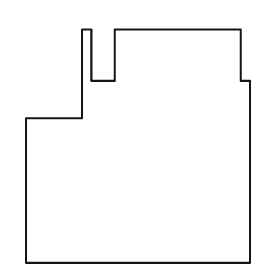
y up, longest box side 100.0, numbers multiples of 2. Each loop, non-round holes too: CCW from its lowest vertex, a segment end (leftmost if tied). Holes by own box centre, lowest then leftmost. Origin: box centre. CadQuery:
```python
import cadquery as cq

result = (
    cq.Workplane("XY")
    .moveTo(-48.0, -50.0)
    .lineTo(48.0, -50.0)
    .lineTo(48.0, 28.0)
    .lineTo(44.0, 28.0)
    .lineTo(44.0, 50.0)
    .lineTo(-10.0, 50.0)
    .lineTo(-10.0, 28.0)
    .lineTo(-20.0, 28.0)
    .lineTo(-20.0, 50.0)
    .lineTo(-24.0, 50.0)
    .lineTo(-24.0, 12.0)
    .lineTo(-48.0, 12.0)
    .close()
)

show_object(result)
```